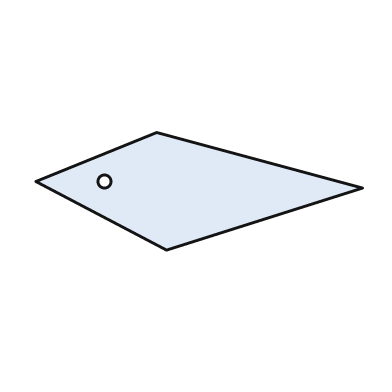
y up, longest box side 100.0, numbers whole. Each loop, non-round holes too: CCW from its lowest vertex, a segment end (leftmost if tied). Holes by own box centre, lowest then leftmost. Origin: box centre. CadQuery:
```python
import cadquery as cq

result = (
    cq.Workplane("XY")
    .moveTo(-10.0, -18.0)
    .lineTo(50.0, 1.0)
    .lineTo(-13.0, 18.0)
    .lineTo(-50.0, 3.0)
    .close()
    .moveTo(-29.0, 3.0)
    .circle(2.0)
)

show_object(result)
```